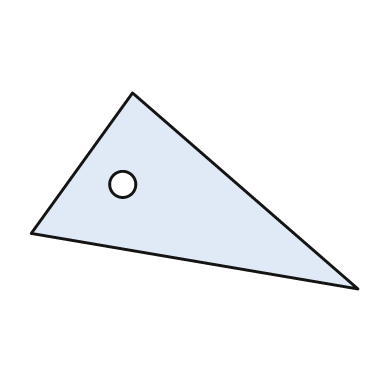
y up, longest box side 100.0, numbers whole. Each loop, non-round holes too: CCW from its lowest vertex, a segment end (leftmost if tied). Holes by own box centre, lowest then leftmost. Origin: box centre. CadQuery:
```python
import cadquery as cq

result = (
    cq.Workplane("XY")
    .moveTo(50.0, -30.0)
    .lineTo(-19.0, 30.0)
    .lineTo(-50.0, -13.0)
    .close()
    .moveTo(-22.0, 2.0)
    .circle(4.0)
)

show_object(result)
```